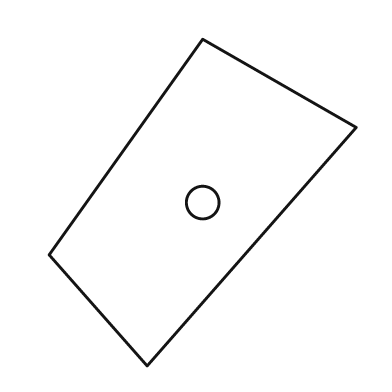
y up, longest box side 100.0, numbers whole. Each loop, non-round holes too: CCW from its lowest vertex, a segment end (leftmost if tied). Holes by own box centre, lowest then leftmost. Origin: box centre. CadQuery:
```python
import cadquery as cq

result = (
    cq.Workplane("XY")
    .moveTo(-17.0, -50.0)
    .lineTo(47.0, 23.0)
    .lineTo(0.0, 50.0)
    .lineTo(-47.0, -16.0)
    .close()
    .moveTo(0.0, 0.0)
    .circle(5.0)
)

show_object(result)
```